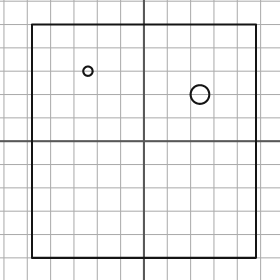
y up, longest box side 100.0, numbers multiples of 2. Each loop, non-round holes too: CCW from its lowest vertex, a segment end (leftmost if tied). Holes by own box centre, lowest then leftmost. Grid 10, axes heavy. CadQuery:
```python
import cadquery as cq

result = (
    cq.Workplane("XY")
    .moveTo(-48.0, -50.0)
    .lineTo(48.0, -50.0)
    .lineTo(48.0, 50.0)
    .lineTo(-48.0, 50.0)
    .close()
    .moveTo(24.0, 20.0)
    .circle(4.0)
    .moveTo(-24.0, 30.0)
    .circle(2.0)
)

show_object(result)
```